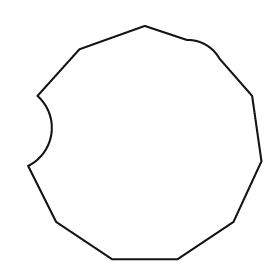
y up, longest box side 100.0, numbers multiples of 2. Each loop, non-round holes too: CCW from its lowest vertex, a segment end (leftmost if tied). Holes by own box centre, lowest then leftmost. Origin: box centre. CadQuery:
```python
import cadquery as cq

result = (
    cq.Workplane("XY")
    .moveTo(-14.0, -50.0)
    .lineTo(14.0, -50.0)
    .lineTo(38.0, -34.0)
    .lineTo(50.0, -8.0)
    .lineTo(46.0, 20.0)
    .lineTo(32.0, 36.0)
    .threePointArc((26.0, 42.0), (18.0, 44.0))
    .lineTo(0.0, 50.0)
    .lineTo(-28.0, 40.0)
    .lineTo(-46.0, 20.0)
    .threePointArc((-40.0, 4.0), (-50.0, -10.0))
    .lineTo(-38.0, -34.0)
    .close()
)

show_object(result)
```